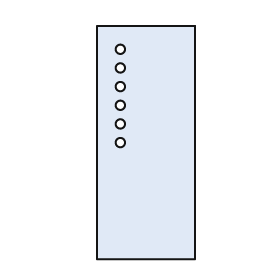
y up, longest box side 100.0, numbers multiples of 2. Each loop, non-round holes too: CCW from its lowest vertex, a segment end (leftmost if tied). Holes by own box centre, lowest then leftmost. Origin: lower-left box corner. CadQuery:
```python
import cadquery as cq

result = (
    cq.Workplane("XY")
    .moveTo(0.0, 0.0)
    .lineTo(42.0, 0.0)
    .lineTo(42.0, 100.0)
    .lineTo(0.0, 100.0)
    .close()
    .moveTo(10.0, 50.0)
    .circle(2.0)
    .moveTo(10.0, 58.0)
    .circle(2.0)
    .moveTo(10.0, 66.0)
    .circle(2.0)
    .moveTo(10.0, 74.0)
    .circle(2.0)
    .moveTo(10.0, 82.0)
    .circle(2.0)
    .moveTo(10.0, 90.0)
    .circle(2.0)
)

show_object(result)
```